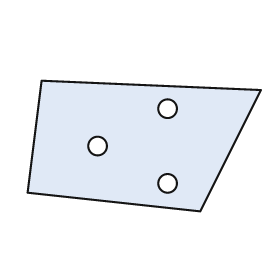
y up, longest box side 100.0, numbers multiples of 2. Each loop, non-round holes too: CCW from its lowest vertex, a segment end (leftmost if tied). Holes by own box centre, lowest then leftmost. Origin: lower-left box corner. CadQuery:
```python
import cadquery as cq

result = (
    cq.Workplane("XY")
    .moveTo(74.0, 0.0)
    .lineTo(100.0, 52.0)
    .lineTo(6.0, 56.0)
    .lineTo(0.0, 8.0)
    .close()
    .moveTo(60.0, 12.0)
    .circle(4.0)
    .moveTo(30.0, 28.0)
    .circle(4.0)
    .moveTo(60.0, 44.0)
    .circle(4.0)
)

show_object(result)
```